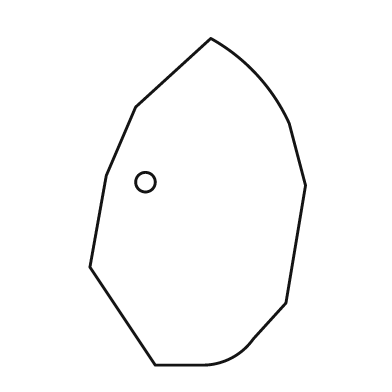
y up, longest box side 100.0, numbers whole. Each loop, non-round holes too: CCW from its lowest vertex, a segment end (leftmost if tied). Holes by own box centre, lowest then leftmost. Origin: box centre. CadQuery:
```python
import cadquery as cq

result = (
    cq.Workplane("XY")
    .moveTo(-13.0, -50.0)
    .lineTo(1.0, -50.0)
    .threePointArc((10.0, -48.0), (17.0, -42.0))
    .lineTo(27.0, -31.0)
    .lineTo(33.0, 5.0)
    .lineTo(28.0, 24.0)
    .threePointArc((18.0, 39.0), (4.0, 50.0))
    .lineTo(-19.0, 29.0)
    .lineTo(-28.0, 8.0)
    .lineTo(-33.0, -20.0)
    .close()
    .moveTo(-16.0, 6.0)
    .circle(3.0)
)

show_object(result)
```